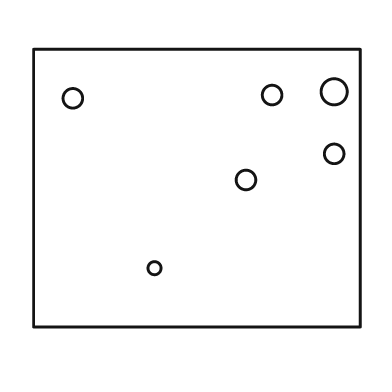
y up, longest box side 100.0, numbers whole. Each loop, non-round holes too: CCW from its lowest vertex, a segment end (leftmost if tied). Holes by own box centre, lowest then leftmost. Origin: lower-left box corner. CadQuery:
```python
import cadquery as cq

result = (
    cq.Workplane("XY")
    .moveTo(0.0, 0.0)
    .lineTo(100.0, 0.0)
    .lineTo(100.0, 85.0)
    .lineTo(0.0, 85.0)
    .close()
    .moveTo(37.0, 18.0)
    .circle(2.0)
    .moveTo(65.0, 45.0)
    .circle(3.0)
    .moveTo(92.0, 53.0)
    .circle(3.0)
    .moveTo(12.0, 70.0)
    .circle(3.0)
    .moveTo(73.0, 71.0)
    .circle(3.0)
    .moveTo(92.0, 72.0)
    .circle(4.0)
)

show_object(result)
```